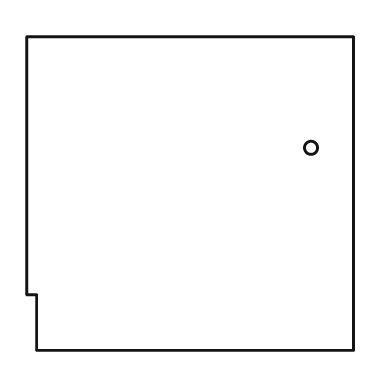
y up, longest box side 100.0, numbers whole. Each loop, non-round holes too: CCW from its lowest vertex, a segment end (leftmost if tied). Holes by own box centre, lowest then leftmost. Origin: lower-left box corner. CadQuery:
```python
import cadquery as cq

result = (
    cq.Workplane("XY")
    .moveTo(3.0, 0.0)
    .lineTo(100.0, 0.0)
    .lineTo(100.0, 96.0)
    .lineTo(0.0, 96.0)
    .lineTo(0.0, 17.0)
    .lineTo(3.0, 17.0)
    .close()
    .moveTo(87.0, 62.0)
    .circle(2.0)
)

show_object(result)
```